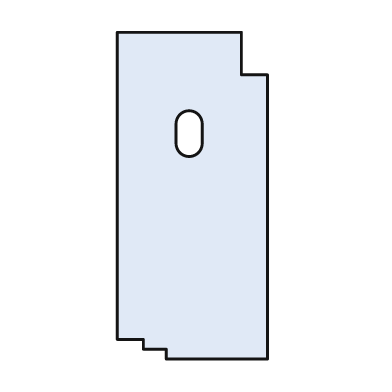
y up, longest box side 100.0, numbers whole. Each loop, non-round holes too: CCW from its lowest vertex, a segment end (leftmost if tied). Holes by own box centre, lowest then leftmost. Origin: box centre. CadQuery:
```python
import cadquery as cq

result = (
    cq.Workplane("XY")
    .moveTo(-8.0, -50.0)
    .lineTo(23.0, -50.0)
    .lineTo(23.0, 37.0)
    .lineTo(15.0, 37.0)
    .lineTo(15.0, 50.0)
    .lineTo(-23.0, 50.0)
    .lineTo(-23.0, -44.0)
    .lineTo(-15.0, -44.0)
    .lineTo(-15.0, -47.0)
    .lineTo(-8.0, -47.0)
    .close()
    .moveTo(-5.0, 16.0)
    .threePointArc((-1.0, 12.0), (3.0, 16.0))
    .lineTo(3.0, 22.0)
    .threePointArc((-1.0, 26.0), (-5.0, 22.0))
    .close()
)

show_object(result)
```